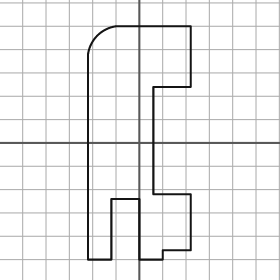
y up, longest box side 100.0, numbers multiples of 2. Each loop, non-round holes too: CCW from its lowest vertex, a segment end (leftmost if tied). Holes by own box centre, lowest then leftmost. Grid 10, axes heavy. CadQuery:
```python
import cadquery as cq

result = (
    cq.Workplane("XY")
    .moveTo(-22.0, -50.0)
    .lineTo(-12.0, -50.0)
    .lineTo(-12.0, -24.0)
    .lineTo(0.0, -24.0)
    .lineTo(0.0, -50.0)
    .lineTo(10.0, -50.0)
    .lineTo(10.0, -46.0)
    .lineTo(22.0, -46.0)
    .lineTo(22.0, -22.0)
    .lineTo(6.0, -22.0)
    .lineTo(6.0, 24.0)
    .lineTo(22.0, 24.0)
    .lineTo(22.0, 50.0)
    .lineTo(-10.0, 50.0)
    .threePointArc((-18.0, 46.0), (-22.0, 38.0))
    .close()
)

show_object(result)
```